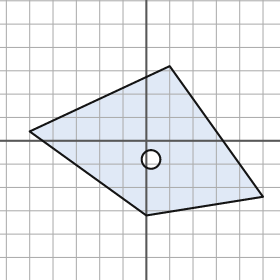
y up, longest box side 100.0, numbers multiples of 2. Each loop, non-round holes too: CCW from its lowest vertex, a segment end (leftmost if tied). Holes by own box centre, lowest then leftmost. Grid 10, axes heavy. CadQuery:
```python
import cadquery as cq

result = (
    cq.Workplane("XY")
    .moveTo(0.0, -32.0)
    .lineTo(50.0, -24.0)
    .lineTo(10.0, 32.0)
    .lineTo(-50.0, 4.0)
    .close()
    .moveTo(2.0, -8.0)
    .circle(4.0)
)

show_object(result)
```